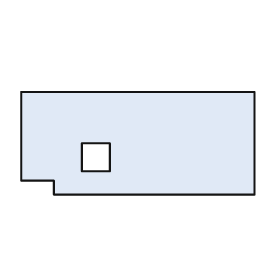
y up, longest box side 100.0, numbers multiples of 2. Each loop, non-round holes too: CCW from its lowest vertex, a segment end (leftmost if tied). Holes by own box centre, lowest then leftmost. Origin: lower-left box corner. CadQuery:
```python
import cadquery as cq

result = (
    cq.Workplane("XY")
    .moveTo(14.0, 0.0)
    .lineTo(100.0, 0.0)
    .lineTo(100.0, 44.0)
    .lineTo(0.0, 44.0)
    .lineTo(0.0, 6.0)
    .lineTo(14.0, 6.0)
    .close()
    .moveTo(26.0, 10.0)
    .lineTo(38.0, 10.0)
    .lineTo(38.0, 22.0)
    .lineTo(26.0, 22.0)
    .close()
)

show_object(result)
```